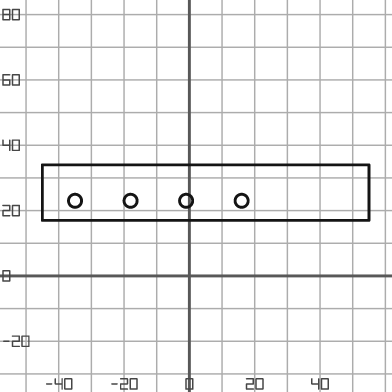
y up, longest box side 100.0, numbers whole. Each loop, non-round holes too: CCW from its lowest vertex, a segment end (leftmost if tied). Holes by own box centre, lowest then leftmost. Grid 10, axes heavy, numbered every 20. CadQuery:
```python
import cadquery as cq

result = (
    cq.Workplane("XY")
    .moveTo(-45.0, 17.0)
    .lineTo(55.0, 17.0)
    .lineTo(55.0, 34.0)
    .lineTo(-45.0, 34.0)
    .close()
    .moveTo(-35.0, 23.0)
    .circle(2.0)
    .moveTo(-18.0, 23.0)
    .circle(2.0)
    .moveTo(-1.0, 23.0)
    .circle(2.0)
    .moveTo(16.0, 23.0)
    .circle(2.0)
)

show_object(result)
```